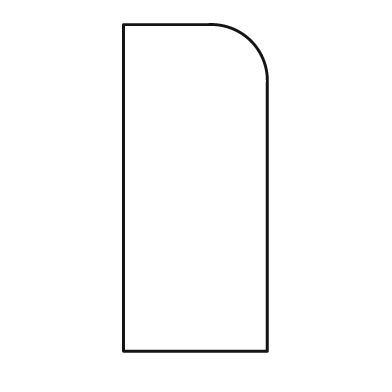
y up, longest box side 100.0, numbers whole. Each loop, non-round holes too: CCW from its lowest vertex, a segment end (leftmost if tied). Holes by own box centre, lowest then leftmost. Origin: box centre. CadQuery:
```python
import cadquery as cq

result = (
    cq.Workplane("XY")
    .moveTo(-22.0, -50.0)
    .lineTo(22.0, -50.0)
    .lineTo(22.0, 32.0)
    .threePointArc((17.0, 45.0), (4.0, 50.0))
    .lineTo(-22.0, 50.0)
    .close()
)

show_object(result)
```